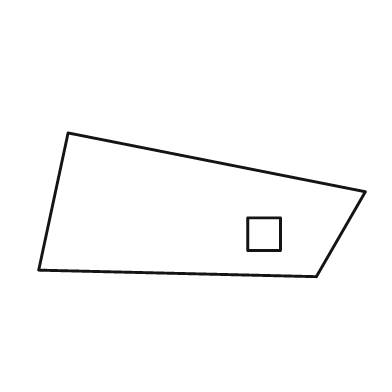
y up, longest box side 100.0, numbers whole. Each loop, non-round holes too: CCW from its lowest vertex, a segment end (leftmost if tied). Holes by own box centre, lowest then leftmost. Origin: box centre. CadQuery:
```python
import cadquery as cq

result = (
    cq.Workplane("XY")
    .moveTo(35.0, -22.0)
    .lineTo(50.0, 4.0)
    .lineTo(-41.0, 22.0)
    .lineTo(-50.0, -20.0)
    .close()
    .moveTo(14.0, -14.0)
    .lineTo(24.0, -14.0)
    .lineTo(24.0, -4.0)
    .lineTo(14.0, -4.0)
    .close()
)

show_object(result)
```